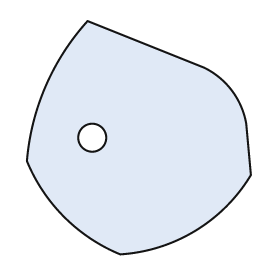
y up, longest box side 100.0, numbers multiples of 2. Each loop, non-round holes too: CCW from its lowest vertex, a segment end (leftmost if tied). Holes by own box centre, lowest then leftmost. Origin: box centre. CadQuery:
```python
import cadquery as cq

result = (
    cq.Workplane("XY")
    .moveTo(-8.0, -50.0)
    .threePointArc((24.0, -40.0), (48.0, -16.0))
    .lineTo(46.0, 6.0)
    .threePointArc((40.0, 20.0), (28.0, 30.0))
    .lineTo(-22.0, 50.0)
    .threePointArc((-40.0, 22.0), (-48.0, -10.0))
    .threePointArc((-32.0, -34.0), (-8.0, -50.0))
    .close()
    .moveTo(-20.0, 0.0)
    .circle(6.0)
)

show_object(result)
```